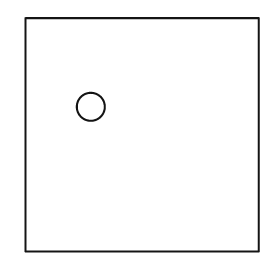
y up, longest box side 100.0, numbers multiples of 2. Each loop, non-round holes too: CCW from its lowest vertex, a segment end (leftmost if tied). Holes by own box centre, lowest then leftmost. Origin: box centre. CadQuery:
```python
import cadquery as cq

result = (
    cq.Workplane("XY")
    .moveTo(-50.0, -50.0)
    .lineTo(50.0, -50.0)
    .lineTo(50.0, 50.0)
    .lineTo(-50.0, 50.0)
    .close()
    .moveTo(-22.0, 12.0)
    .circle(6.0)
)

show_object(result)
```